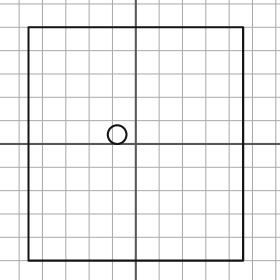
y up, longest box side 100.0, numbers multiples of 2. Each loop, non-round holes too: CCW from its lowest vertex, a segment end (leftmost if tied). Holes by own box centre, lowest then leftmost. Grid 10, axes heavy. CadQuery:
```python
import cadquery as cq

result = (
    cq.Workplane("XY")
    .moveTo(-46.0, -50.0)
    .lineTo(46.0, -50.0)
    .lineTo(46.0, 50.0)
    .lineTo(-46.0, 50.0)
    .close()
    .moveTo(-8.0, 4.0)
    .circle(4.0)
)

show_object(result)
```